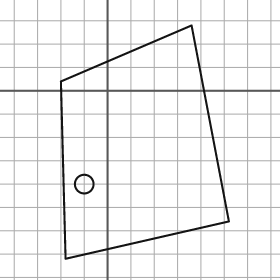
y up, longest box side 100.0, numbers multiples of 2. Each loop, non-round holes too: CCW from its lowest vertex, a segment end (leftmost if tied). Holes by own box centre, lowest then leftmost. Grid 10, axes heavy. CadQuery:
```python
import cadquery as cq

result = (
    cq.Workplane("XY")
    .moveTo(-18.0, -72.0)
    .lineTo(52.0, -56.0)
    .lineTo(36.0, 28.0)
    .lineTo(-20.0, 4.0)
    .close()
    .moveTo(-10.0, -40.0)
    .circle(4.0)
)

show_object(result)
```